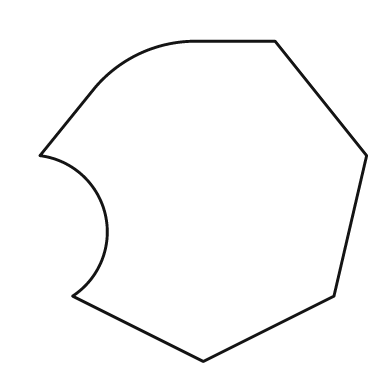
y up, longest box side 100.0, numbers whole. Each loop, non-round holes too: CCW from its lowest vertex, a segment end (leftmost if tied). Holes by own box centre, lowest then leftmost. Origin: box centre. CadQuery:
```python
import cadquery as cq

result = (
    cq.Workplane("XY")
    .moveTo(0.0, -49.0)
    .lineTo(40.0, -29.0)
    .lineTo(50.0, 14.0)
    .lineTo(22.0, 49.0)
    .lineTo(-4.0, 49.0)
    .threePointArc((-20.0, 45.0), (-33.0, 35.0))
    .lineTo(-50.0, 14.0)
    .threePointArc((-30.0, -4.0), (-40.0, -29.0))
    .close()
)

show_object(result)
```